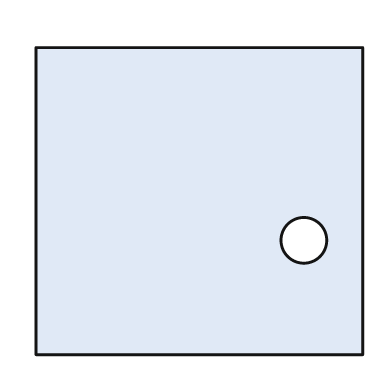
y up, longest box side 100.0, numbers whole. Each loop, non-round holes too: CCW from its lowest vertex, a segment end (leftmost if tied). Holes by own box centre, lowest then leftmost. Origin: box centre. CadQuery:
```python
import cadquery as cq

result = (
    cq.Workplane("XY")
    .moveTo(-50.0, -47.0)
    .lineTo(50.0, -47.0)
    .lineTo(50.0, 47.0)
    .lineTo(-50.0, 47.0)
    .close()
    .moveTo(32.0, -12.0)
    .circle(7.0)
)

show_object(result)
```